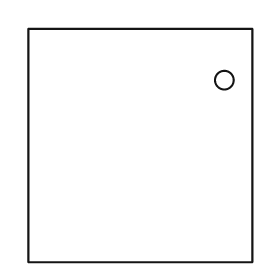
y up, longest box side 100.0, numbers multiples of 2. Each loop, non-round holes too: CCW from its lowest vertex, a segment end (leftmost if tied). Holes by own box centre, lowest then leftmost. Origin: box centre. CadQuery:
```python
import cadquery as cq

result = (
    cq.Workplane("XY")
    .moveTo(-48.0, -50.0)
    .lineTo(48.0, -50.0)
    .lineTo(48.0, 50.0)
    .lineTo(-48.0, 50.0)
    .close()
    .moveTo(36.0, 28.0)
    .circle(4.0)
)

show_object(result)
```